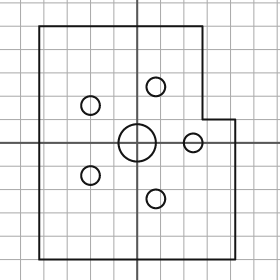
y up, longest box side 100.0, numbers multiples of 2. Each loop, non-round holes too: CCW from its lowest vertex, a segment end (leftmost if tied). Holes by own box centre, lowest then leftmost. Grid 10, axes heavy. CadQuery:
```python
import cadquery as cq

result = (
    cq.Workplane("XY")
    .moveTo(-42.0, -50.0)
    .lineTo(42.0, -50.0)
    .lineTo(42.0, 10.0)
    .lineTo(28.0, 10.0)
    .lineTo(28.0, 50.0)
    .lineTo(-42.0, 50.0)
    .close()
    .moveTo(8.0, -24.0)
    .circle(4.0)
    .moveTo(-20.0, -14.0)
    .circle(4.0)
    .moveTo(0.0, 0.0)
    .circle(8.0)
    .moveTo(24.0, 0.0)
    .circle(4.0)
    .moveTo(-20.0, 16.0)
    .circle(4.0)
    .moveTo(8.0, 24.0)
    .circle(4.0)
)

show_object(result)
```